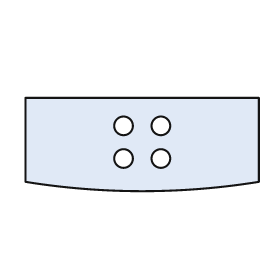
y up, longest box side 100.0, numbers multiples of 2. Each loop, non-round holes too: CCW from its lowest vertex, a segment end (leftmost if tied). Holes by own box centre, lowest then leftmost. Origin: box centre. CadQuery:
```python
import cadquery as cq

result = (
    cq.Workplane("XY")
    .moveTo(-50.0, -16.0)
    .threePointArc((0.0, -20.0), (50.0, -16.0))
    .lineTo(50.0, 20.0)
    .lineTo(-50.0, 20.0)
    .close()
    .moveTo(-8.0, -6.0)
    .circle(4.0)
    .moveTo(8.0, -6.0)
    .circle(4.0)
    .moveTo(-8.0, 8.0)
    .circle(4.0)
    .moveTo(8.0, 8.0)
    .circle(4.0)
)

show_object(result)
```